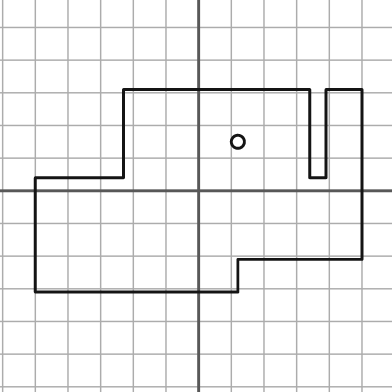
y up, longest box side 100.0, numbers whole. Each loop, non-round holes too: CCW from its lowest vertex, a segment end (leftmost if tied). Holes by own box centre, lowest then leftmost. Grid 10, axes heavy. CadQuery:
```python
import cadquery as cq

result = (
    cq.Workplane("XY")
    .moveTo(-50.0, -31.0)
    .lineTo(12.0, -31.0)
    .lineTo(12.0, -21.0)
    .lineTo(50.0, -21.0)
    .lineTo(50.0, 31.0)
    .lineTo(39.0, 31.0)
    .lineTo(39.0, 4.0)
    .lineTo(34.0, 4.0)
    .lineTo(34.0, 31.0)
    .lineTo(-23.0, 31.0)
    .lineTo(-23.0, 4.0)
    .lineTo(-50.0, 4.0)
    .close()
    .moveTo(12.0, 15.0)
    .circle(2.0)
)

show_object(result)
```